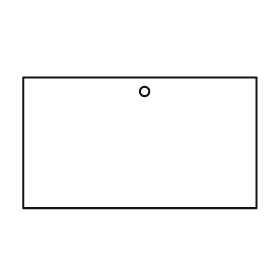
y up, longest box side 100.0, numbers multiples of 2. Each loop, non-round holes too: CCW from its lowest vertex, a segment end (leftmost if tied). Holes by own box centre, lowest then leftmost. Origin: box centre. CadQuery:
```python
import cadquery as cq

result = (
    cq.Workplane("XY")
    .moveTo(-50.0, -28.0)
    .lineTo(50.0, -28.0)
    .lineTo(50.0, 28.0)
    .lineTo(-50.0, 28.0)
    .close()
    .moveTo(2.0, 22.0)
    .circle(2.0)
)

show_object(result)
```